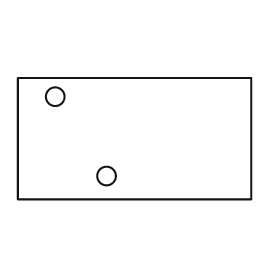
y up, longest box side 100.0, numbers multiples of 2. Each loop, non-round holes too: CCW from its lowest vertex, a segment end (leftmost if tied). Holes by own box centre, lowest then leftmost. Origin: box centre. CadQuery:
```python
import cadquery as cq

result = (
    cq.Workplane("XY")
    .moveTo(-50.0, -26.0)
    .lineTo(50.0, -26.0)
    .lineTo(50.0, 26.0)
    .lineTo(-50.0, 26.0)
    .close()
    .moveTo(-12.0, -16.0)
    .circle(4.0)
    .moveTo(-34.0, 18.0)
    .circle(4.0)
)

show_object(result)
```